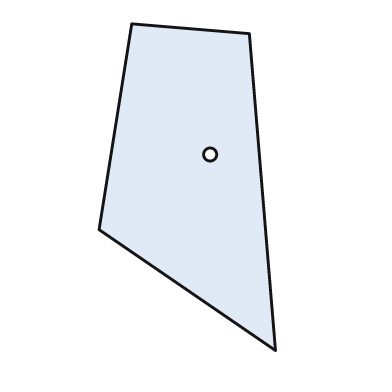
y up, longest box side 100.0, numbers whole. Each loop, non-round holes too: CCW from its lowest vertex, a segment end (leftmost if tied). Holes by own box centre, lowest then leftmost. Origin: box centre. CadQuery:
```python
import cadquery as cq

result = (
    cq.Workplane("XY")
    .moveTo(27.0, -50.0)
    .lineTo(19.0, 47.0)
    .lineTo(-17.0, 50.0)
    .lineTo(-27.0, -13.0)
    .close()
    .moveTo(7.0, 10.0)
    .circle(2.0)
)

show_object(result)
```